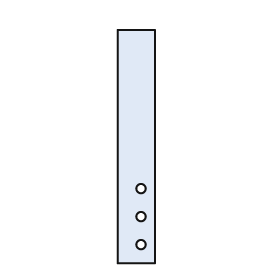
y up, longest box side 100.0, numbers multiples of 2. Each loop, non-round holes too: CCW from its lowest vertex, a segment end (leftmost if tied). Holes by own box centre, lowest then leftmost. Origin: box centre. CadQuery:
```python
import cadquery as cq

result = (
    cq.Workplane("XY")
    .moveTo(-8.0, -50.0)
    .lineTo(8.0, -50.0)
    .lineTo(8.0, 50.0)
    .lineTo(-8.0, 50.0)
    .close()
    .moveTo(2.0, -42.0)
    .circle(2.0)
    .moveTo(2.0, -30.0)
    .circle(2.0)
    .moveTo(2.0, -18.0)
    .circle(2.0)
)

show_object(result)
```